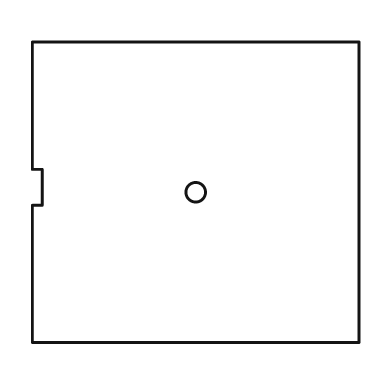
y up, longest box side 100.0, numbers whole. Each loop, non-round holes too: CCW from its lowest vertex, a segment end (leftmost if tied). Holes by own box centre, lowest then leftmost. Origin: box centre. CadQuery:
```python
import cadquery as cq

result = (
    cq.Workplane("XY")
    .moveTo(-50.0, -46.0)
    .lineTo(50.0, -46.0)
    .lineTo(50.0, 46.0)
    .lineTo(-50.0, 46.0)
    .lineTo(-50.0, 7.0)
    .lineTo(-47.0, 7.0)
    .lineTo(-47.0, -4.0)
    .lineTo(-50.0, -4.0)
    .close()
    .moveTo(0.0, 0.0)
    .circle(3.0)
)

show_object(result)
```